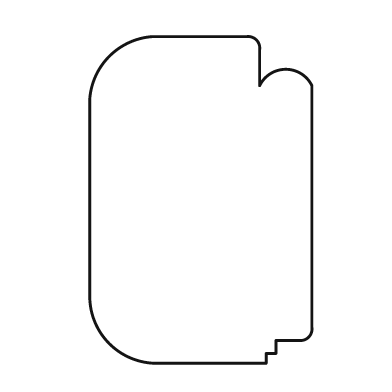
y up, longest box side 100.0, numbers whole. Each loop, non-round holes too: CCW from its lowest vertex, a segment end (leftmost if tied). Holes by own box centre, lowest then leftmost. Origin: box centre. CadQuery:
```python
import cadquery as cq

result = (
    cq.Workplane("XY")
    .moveTo(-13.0, -50.0)
    .lineTo(20.0, -50.0)
    .lineTo(20.0, -47.0)
    .lineTo(23.0, -47.0)
    .lineTo(23.0, -43.0)
    .lineTo(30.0, -43.0)
    .threePointArc((33.0, -42.0), (34.0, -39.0))
    .lineTo(34.0, 35.0)
    .threePointArc((26.0, 40.0), (18.0, 35.0))
    .lineTo(18.0, 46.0)
    .threePointArc((17.0, 49.0), (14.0, 50.0))
    .lineTo(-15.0, 50.0)
    .threePointArc((-28.0, 44.0), (-34.0, 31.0))
    .lineTo(-34.0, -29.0)
    .threePointArc((-28.0, -44.0), (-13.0, -50.0))
    .close()
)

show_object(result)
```